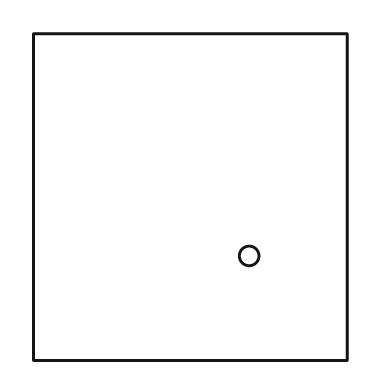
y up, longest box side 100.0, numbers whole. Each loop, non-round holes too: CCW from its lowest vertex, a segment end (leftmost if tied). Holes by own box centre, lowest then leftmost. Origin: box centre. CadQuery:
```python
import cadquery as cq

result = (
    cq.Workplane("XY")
    .moveTo(-48.0, -50.0)
    .lineTo(48.0, -50.0)
    .lineTo(48.0, 50.0)
    .lineTo(-48.0, 50.0)
    .close()
    .moveTo(18.0, -18.0)
    .circle(3.0)
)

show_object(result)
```